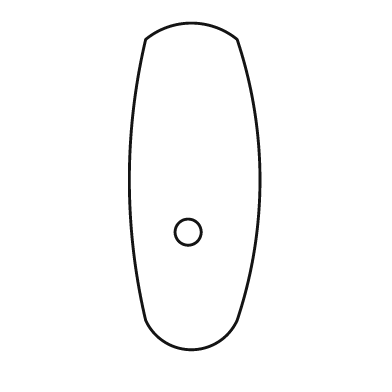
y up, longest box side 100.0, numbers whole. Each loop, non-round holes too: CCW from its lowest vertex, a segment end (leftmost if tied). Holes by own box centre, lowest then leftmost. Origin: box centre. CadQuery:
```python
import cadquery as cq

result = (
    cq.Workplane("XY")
    .moveTo(-15.0, -41.0)
    .threePointArc((-1.0, -50.0), (13.0, -41.0))
    .threePointArc((20.0, 2.0), (13.0, 45.0))
    .threePointArc((-1.0, 50.0), (-15.0, 45.0))
    .threePointArc((-20.0, 2.0), (-15.0, -41.0))
    .close()
    .moveTo(-2.0, -14.0)
    .circle(4.0)
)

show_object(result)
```